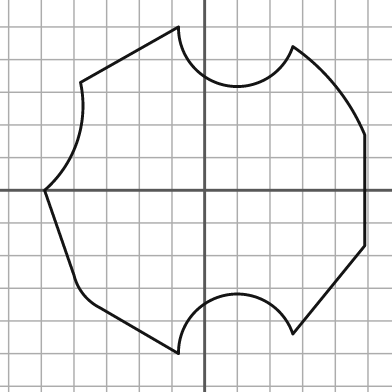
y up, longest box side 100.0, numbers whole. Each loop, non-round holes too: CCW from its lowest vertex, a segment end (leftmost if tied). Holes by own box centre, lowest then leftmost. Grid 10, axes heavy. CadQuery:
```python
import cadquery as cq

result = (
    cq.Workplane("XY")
    .moveTo(-8.0, -50.0)
    .threePointArc((7.0, -32.0), (27.0, -44.0))
    .lineTo(49.0, -17.0)
    .lineTo(49.0, 17.0)
    .threePointArc((40.0, 32.0), (27.0, 44.0))
    .threePointArc((7.0, 32.0), (-8.0, 50.0))
    .lineTo(-38.0, 33.0)
    .threePointArc((-39.0, 15.0), (-49.0, 0.0))
    .lineTo(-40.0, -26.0)
    .threePointArc((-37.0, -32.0), (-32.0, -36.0))
    .close()
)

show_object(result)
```